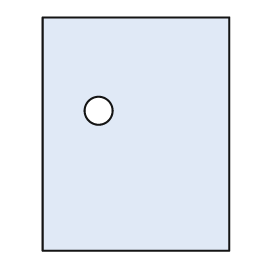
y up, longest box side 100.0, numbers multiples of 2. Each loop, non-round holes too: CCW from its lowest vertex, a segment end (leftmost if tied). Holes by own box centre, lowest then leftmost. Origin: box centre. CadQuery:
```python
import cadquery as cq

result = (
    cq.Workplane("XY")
    .moveTo(-40.0, -50.0)
    .lineTo(40.0, -50.0)
    .lineTo(40.0, 50.0)
    .lineTo(-40.0, 50.0)
    .close()
    .moveTo(-16.0, 10.0)
    .circle(6.0)
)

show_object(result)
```